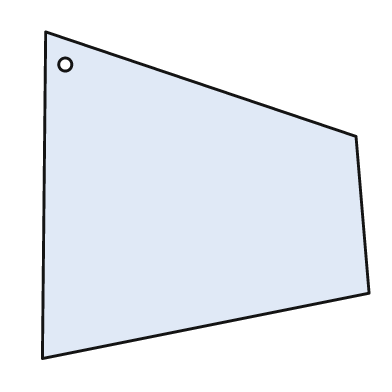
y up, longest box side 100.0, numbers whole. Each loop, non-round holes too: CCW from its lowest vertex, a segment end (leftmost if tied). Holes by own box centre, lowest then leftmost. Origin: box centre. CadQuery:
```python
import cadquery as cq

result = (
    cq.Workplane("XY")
    .moveTo(-50.0, -50.0)
    .lineTo(50.0, -30.0)
    .lineTo(46.0, 18.0)
    .lineTo(-49.0, 50.0)
    .close()
    .moveTo(-43.0, 40.0)
    .circle(2.0)
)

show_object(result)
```